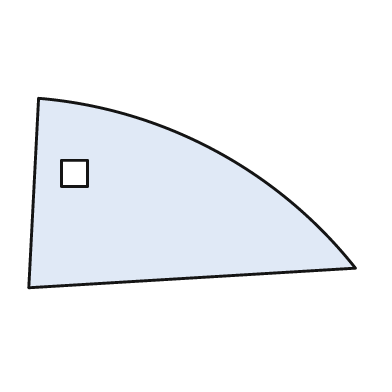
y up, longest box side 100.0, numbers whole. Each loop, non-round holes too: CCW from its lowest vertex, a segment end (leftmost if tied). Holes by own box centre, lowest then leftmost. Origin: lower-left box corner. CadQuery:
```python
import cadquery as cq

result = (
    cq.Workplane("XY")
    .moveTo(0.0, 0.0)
    .lineTo(100.0, 6.0)
    .threePointArc((57.0, 42.0), (3.0, 58.0))
    .close()
    .moveTo(10.0, 31.0)
    .lineTo(18.0, 31.0)
    .lineTo(18.0, 39.0)
    .lineTo(10.0, 39.0)
    .close()
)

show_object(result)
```